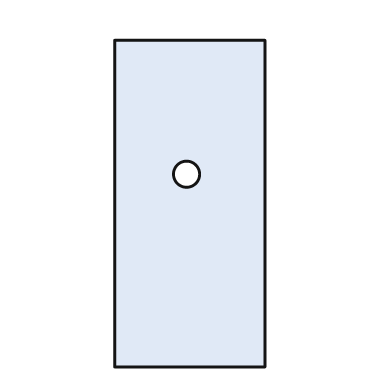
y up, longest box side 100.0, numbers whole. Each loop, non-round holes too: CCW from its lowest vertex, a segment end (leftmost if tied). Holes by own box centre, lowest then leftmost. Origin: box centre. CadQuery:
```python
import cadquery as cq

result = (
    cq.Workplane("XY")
    .moveTo(-23.0, -50.0)
    .lineTo(23.0, -50.0)
    .lineTo(23.0, 50.0)
    .lineTo(-23.0, 50.0)
    .close()
    .moveTo(-1.0, 9.0)
    .circle(4.0)
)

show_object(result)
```